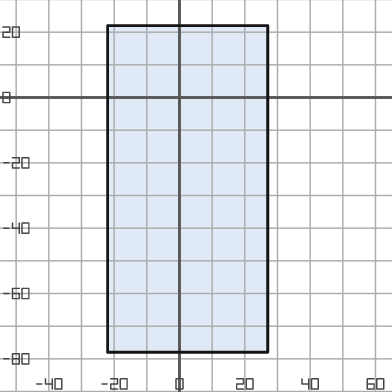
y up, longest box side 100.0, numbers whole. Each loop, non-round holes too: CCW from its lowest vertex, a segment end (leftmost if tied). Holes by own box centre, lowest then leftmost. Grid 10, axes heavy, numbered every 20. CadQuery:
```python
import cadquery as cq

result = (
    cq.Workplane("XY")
    .moveTo(-22.0, -78.0)
    .lineTo(27.0, -78.0)
    .lineTo(27.0, 22.0)
    .lineTo(-22.0, 22.0)
    .close()
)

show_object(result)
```